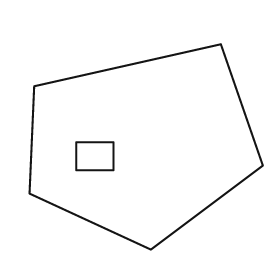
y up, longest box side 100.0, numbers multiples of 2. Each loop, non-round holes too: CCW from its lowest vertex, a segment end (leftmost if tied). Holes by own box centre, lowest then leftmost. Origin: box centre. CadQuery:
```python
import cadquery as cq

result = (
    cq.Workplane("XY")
    .moveTo(2.0, -44.0)
    .lineTo(50.0, -8.0)
    .lineTo(32.0, 44.0)
    .lineTo(-48.0, 26.0)
    .lineTo(-50.0, -20.0)
    .close()
    .moveTo(-30.0, -10.0)
    .lineTo(-14.0, -10.0)
    .lineTo(-14.0, 2.0)
    .lineTo(-30.0, 2.0)
    .close()
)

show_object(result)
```